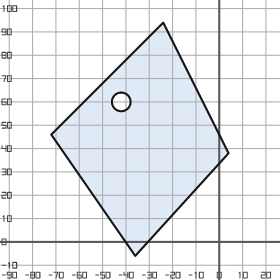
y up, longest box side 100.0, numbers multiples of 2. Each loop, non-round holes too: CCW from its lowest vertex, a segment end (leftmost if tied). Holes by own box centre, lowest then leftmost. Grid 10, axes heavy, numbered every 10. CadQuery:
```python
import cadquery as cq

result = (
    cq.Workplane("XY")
    .moveTo(-36.0, -6.0)
    .lineTo(4.0, 38.0)
    .lineTo(-24.0, 94.0)
    .lineTo(-72.0, 46.0)
    .close()
    .moveTo(-42.0, 60.0)
    .circle(4.0)
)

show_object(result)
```